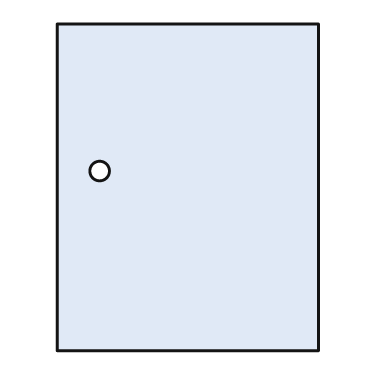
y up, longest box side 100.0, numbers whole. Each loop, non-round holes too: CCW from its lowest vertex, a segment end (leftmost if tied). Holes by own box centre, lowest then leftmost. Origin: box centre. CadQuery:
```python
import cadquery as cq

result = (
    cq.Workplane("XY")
    .moveTo(-40.0, -50.0)
    .lineTo(40.0, -50.0)
    .lineTo(40.0, 50.0)
    .lineTo(-40.0, 50.0)
    .close()
    .moveTo(-27.0, 5.0)
    .circle(3.0)
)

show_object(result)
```